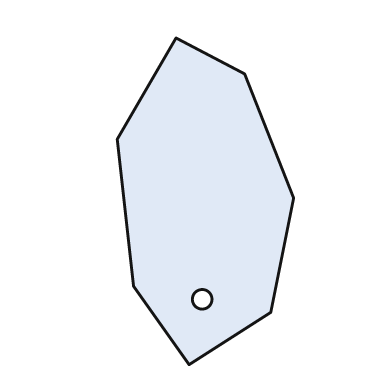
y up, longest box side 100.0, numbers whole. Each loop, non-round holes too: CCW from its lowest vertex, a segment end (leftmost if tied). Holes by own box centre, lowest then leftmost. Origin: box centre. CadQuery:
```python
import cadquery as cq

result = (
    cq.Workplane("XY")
    .moveTo(-5.0, -50.0)
    .lineTo(20.0, -34.0)
    .lineTo(27.0, 1.0)
    .lineTo(12.0, 39.0)
    .lineTo(-9.0, 50.0)
    .lineTo(-27.0, 19.0)
    .lineTo(-22.0, -26.0)
    .close()
    .moveTo(-1.0, -30.0)
    .circle(3.0)
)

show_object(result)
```